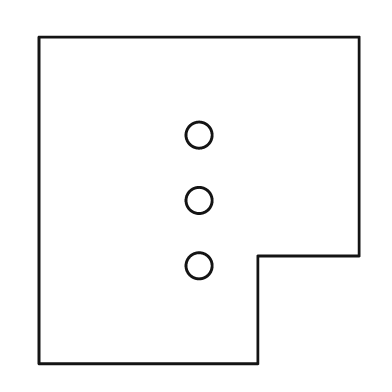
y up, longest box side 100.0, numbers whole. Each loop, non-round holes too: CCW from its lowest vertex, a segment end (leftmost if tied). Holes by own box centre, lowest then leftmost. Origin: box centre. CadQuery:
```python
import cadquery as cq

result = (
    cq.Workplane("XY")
    .moveTo(-49.0, -50.0)
    .lineTo(18.0, -50.0)
    .lineTo(18.0, -17.0)
    .lineTo(49.0, -17.0)
    .lineTo(49.0, 50.0)
    .lineTo(-49.0, 50.0)
    .close()
    .moveTo(0.0, -20.0)
    .circle(4.0)
    .moveTo(0.0, 0.0)
    .circle(4.0)
    .moveTo(0.0, 20.0)
    .circle(4.0)
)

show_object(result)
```